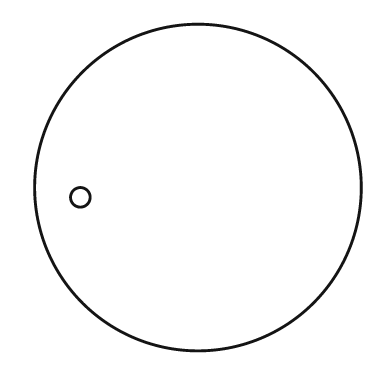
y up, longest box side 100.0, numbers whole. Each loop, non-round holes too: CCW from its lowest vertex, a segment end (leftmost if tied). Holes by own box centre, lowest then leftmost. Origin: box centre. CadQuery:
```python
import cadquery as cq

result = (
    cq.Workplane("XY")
    .moveTo(0.0, 0.0)
    .circle(50.0)
    .moveTo(-36.0, -3.0)
    .circle(3.0)
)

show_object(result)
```